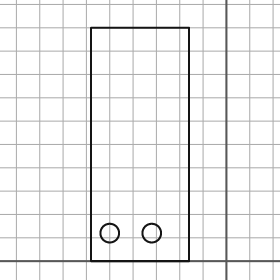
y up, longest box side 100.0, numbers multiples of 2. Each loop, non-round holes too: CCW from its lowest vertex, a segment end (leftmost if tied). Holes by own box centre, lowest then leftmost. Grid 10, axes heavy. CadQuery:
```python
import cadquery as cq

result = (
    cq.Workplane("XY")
    .moveTo(-58.0, 0.0)
    .lineTo(-16.0, 0.0)
    .lineTo(-16.0, 100.0)
    .lineTo(-58.0, 100.0)
    .close()
    .moveTo(-50.0, 12.0)
    .circle(4.0)
    .moveTo(-32.0, 12.0)
    .circle(4.0)
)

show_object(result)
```